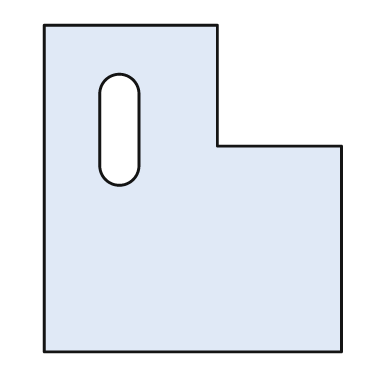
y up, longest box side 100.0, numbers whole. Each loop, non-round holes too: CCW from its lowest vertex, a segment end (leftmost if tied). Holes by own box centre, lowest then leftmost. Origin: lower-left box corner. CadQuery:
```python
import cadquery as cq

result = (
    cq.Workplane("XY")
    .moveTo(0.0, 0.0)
    .lineTo(91.0, 0.0)
    .lineTo(91.0, 63.0)
    .lineTo(53.0, 63.0)
    .lineTo(53.0, 100.0)
    .lineTo(0.0, 100.0)
    .close()
    .moveTo(17.0, 57.0)
    .threePointArc((23.0, 51.0), (29.0, 57.0))
    .lineTo(29.0, 79.0)
    .threePointArc((23.0, 85.0), (17.0, 79.0))
    .close()
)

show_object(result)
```